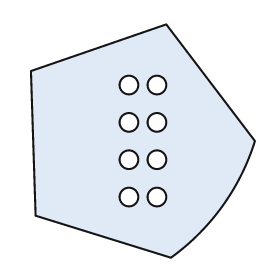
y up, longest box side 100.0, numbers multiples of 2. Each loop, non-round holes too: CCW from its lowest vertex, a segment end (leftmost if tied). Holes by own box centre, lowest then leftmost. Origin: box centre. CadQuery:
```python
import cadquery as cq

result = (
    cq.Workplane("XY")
    .moveTo(12.0, -50.0)
    .threePointArc((34.0, -28.0), (48.0, 0.0))
    .lineTo(10.0, 50.0)
    .lineTo(-48.0, 30.0)
    .lineTo(-46.0, -32.0)
    .close()
    .moveTo(-6.0, -24.0)
    .circle(4.0)
    .moveTo(6.0, -24.0)
    .circle(4.0)
    .moveTo(-6.0, -8.0)
    .circle(4.0)
    .moveTo(6.0, -8.0)
    .circle(4.0)
    .moveTo(-6.0, 8.0)
    .circle(4.0)
    .moveTo(6.0, 8.0)
    .circle(4.0)
    .moveTo(-6.0, 24.0)
    .circle(4.0)
    .moveTo(6.0, 24.0)
    .circle(4.0)
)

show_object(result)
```